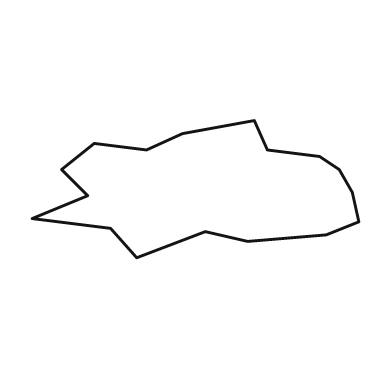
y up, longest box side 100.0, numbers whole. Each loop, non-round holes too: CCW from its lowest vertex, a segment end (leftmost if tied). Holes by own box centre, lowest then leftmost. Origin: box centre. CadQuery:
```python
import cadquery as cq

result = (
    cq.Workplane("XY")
    .moveTo(-18.0, -21.0)
    .lineTo(3.0, -13.0)
    .lineTo(16.0, -16.0)
    .lineTo(40.0, -14.0)
    .lineTo(50.0, -10.0)
    .lineTo(48.0, -1.0)
    .lineTo(44.0, 6.0)
    .lineTo(38.0, 10.0)
    .lineTo(22.0, 12.0)
    .lineTo(18.0, 21.0)
    .lineTo(-4.0, 17.0)
    .lineTo(-15.0, 12.0)
    .lineTo(-31.0, 14.0)
    .lineTo(-41.0, 6.0)
    .lineTo(-33.0, -2.0)
    .lineTo(-50.0, -9.0)
    .lineTo(-26.0, -12.0)
    .close()
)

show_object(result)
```